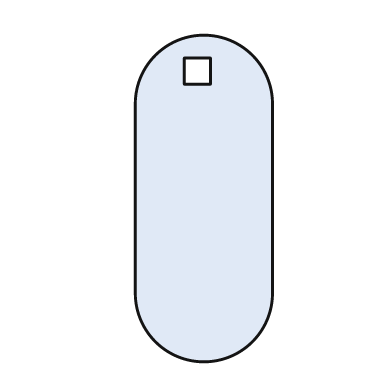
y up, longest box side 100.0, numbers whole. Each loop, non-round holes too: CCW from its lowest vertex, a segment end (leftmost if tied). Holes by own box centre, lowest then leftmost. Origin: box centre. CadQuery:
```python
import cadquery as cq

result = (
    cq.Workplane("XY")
    .moveTo(-21.0, -29.0)
    .threePointArc((0.0, -50.0), (21.0, -29.0))
    .lineTo(21.0, 29.0)
    .threePointArc((0.0, 50.0), (-21.0, 29.0))
    .close()
    .moveTo(-6.0, 35.0)
    .lineTo(2.0, 35.0)
    .lineTo(2.0, 43.0)
    .lineTo(-6.0, 43.0)
    .close()
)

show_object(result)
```